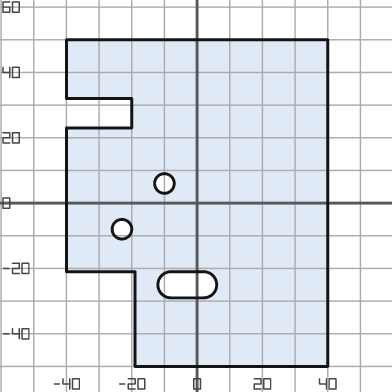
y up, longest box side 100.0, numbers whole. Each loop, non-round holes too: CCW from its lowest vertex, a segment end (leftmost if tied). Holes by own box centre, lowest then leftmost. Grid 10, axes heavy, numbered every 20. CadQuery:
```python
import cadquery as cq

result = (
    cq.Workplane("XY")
    .moveTo(-19.0, -50.0)
    .lineTo(40.0, -50.0)
    .lineTo(40.0, 50.0)
    .lineTo(-40.0, 50.0)
    .lineTo(-40.0, 32.0)
    .lineTo(-20.0, 32.0)
    .lineTo(-20.0, 23.0)
    .lineTo(-40.0, 23.0)
    .lineTo(-40.0, -21.0)
    .lineTo(-19.0, -21.0)
    .close()
    .moveTo(-8.0, -29.0)
    .lineTo(2.0, -29.0)
    .threePointArc((6.0, -25.0), (2.0, -21.0))
    .lineTo(-8.0, -21.0)
    .threePointArc((-12.0, -25.0), (-8.0, -29.0))
    .close()
    .moveTo(-23.0, -8.0)
    .circle(3.0)
    .moveTo(-10.0, 6.0)
    .circle(3.0)
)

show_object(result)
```